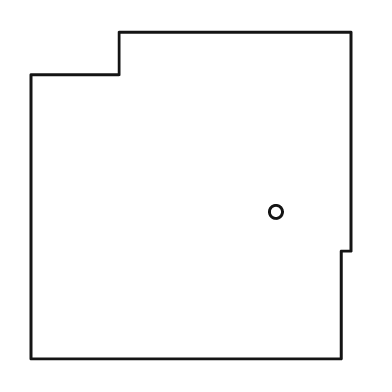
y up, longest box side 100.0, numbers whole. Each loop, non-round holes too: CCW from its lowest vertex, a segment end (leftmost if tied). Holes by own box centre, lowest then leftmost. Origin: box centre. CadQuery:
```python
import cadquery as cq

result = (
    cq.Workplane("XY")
    .moveTo(-49.0, -50.0)
    .lineTo(46.0, -50.0)
    .lineTo(46.0, -17.0)
    .lineTo(49.0, -17.0)
    .lineTo(49.0, 50.0)
    .lineTo(-22.0, 50.0)
    .lineTo(-22.0, 37.0)
    .lineTo(-49.0, 37.0)
    .close()
    .moveTo(26.0, -5.0)
    .circle(2.0)
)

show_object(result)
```